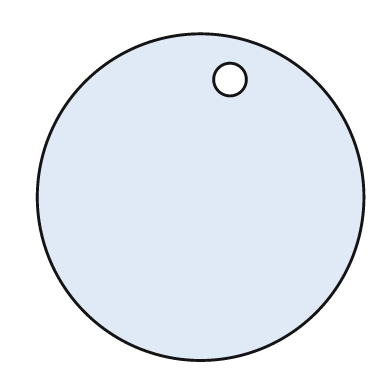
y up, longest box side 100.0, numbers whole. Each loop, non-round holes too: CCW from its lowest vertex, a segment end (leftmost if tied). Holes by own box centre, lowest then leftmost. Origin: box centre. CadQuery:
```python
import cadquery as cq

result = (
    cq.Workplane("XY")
    .moveTo(0.0, 0.0)
    .circle(50.0)
    .moveTo(9.0, 36.0)
    .circle(5.0)
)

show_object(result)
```